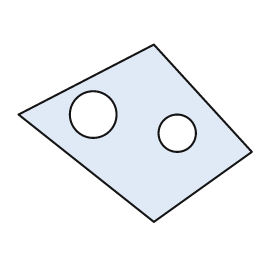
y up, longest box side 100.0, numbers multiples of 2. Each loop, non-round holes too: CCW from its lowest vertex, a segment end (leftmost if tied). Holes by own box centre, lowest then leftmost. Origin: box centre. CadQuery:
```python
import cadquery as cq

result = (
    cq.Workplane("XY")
    .moveTo(8.0, -38.0)
    .lineTo(50.0, -8.0)
    .lineTo(8.0, 38.0)
    .lineTo(-50.0, 8.0)
    .close()
    .moveTo(18.0, 0.0)
    .circle(8.0)
    .moveTo(-18.0, 8.0)
    .circle(10.0)
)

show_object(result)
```